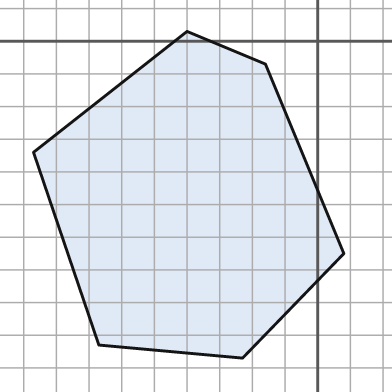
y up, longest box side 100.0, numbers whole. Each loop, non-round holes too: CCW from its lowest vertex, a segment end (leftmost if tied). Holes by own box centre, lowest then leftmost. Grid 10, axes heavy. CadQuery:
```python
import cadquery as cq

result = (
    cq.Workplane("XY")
    .moveTo(-23.0, -97.0)
    .lineTo(8.0, -65.0)
    .lineTo(-16.0, -7.0)
    .lineTo(-40.0, 3.0)
    .lineTo(-87.0, -34.0)
    .lineTo(-67.0, -93.0)
    .close()
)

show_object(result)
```